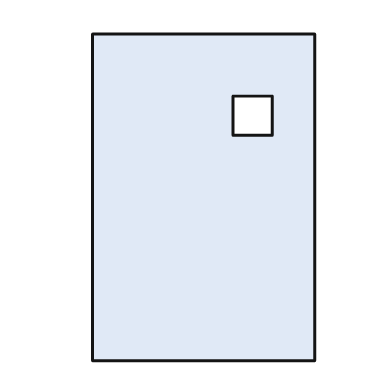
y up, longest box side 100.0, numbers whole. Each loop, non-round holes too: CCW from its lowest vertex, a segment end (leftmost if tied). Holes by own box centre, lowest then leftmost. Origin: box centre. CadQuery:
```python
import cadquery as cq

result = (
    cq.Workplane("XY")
    .moveTo(-34.0, -50.0)
    .lineTo(34.0, -50.0)
    .lineTo(34.0, 50.0)
    .lineTo(-34.0, 50.0)
    .close()
    .moveTo(9.0, 19.0)
    .lineTo(21.0, 19.0)
    .lineTo(21.0, 31.0)
    .lineTo(9.0, 31.0)
    .close()
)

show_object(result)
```